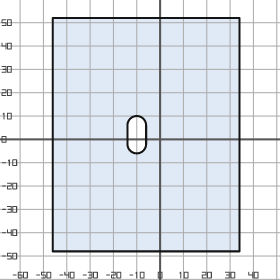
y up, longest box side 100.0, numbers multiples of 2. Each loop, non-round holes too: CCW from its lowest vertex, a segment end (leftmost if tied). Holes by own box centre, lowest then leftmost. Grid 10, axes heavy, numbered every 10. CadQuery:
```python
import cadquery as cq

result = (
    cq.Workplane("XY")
    .moveTo(-46.0, -48.0)
    .lineTo(34.0, -48.0)
    .lineTo(34.0, 52.0)
    .lineTo(-46.0, 52.0)
    .close()
    .moveTo(-14.0, -2.0)
    .threePointArc((-10.0, -6.0), (-6.0, -2.0))
    .lineTo(-6.0, 6.0)
    .threePointArc((-10.0, 10.0), (-14.0, 6.0))
    .close()
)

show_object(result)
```